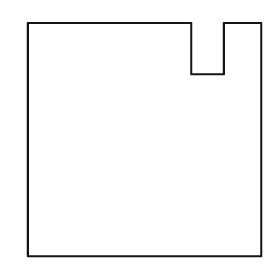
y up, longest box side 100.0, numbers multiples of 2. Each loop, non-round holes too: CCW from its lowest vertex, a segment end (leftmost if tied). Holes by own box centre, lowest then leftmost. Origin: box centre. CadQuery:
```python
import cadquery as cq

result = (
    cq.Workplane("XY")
    .moveTo(-50.0, -50.0)
    .lineTo(50.0, -50.0)
    .lineTo(50.0, 50.0)
    .lineTo(34.0, 50.0)
    .lineTo(34.0, 28.0)
    .lineTo(20.0, 28.0)
    .lineTo(20.0, 50.0)
    .lineTo(-50.0, 50.0)
    .close()
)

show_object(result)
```